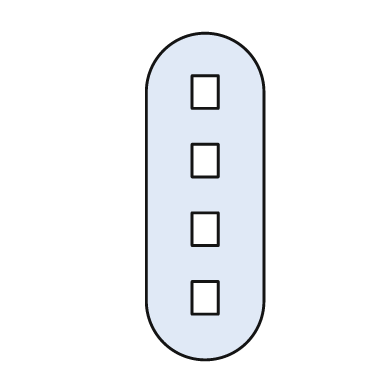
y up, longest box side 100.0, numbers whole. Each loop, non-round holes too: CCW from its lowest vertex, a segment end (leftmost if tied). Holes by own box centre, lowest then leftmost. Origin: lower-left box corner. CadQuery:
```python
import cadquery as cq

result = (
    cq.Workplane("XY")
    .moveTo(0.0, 18.0)
    .threePointArc((18.0, 0.0), (36.0, 18.0))
    .lineTo(36.0, 82.0)
    .threePointArc((18.0, 100.0), (0.0, 82.0))
    .close()
    .moveTo(14.0, 14.0)
    .lineTo(22.0, 14.0)
    .lineTo(22.0, 24.0)
    .lineTo(14.0, 24.0)
    .close()
    .moveTo(14.0, 35.0)
    .lineTo(22.0, 35.0)
    .lineTo(22.0, 45.0)
    .lineTo(14.0, 45.0)
    .close()
    .moveTo(14.0, 56.0)
    .lineTo(22.0, 56.0)
    .lineTo(22.0, 66.0)
    .lineTo(14.0, 66.0)
    .close()
    .moveTo(14.0, 77.0)
    .lineTo(22.0, 77.0)
    .lineTo(22.0, 87.0)
    .lineTo(14.0, 87.0)
    .close()
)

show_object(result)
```